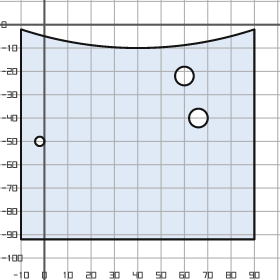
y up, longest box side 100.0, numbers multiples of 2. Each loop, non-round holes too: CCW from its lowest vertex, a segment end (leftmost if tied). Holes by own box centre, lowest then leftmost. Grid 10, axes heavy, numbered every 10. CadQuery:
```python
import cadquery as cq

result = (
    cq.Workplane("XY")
    .moveTo(-10.0, -92.0)
    .lineTo(90.0, -92.0)
    .lineTo(90.0, -2.0)
    .threePointArc((40.0, -10.0), (-10.0, -2.0))
    .close()
    .moveTo(-2.0, -50.0)
    .circle(2.0)
    .moveTo(66.0, -40.0)
    .circle(4.0)
    .moveTo(60.0, -22.0)
    .circle(4.0)
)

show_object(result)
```